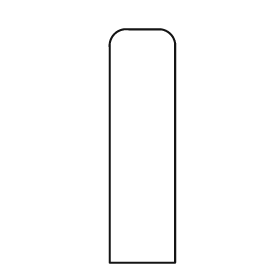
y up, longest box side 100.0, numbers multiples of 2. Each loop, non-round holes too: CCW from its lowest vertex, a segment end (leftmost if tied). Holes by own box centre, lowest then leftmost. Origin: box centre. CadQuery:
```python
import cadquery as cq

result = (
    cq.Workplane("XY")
    .moveTo(-14.0, -50.0)
    .lineTo(14.0, -50.0)
    .lineTo(14.0, 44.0)
    .threePointArc((12.0, 48.0), (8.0, 50.0))
    .lineTo(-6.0, 50.0)
    .threePointArc((-12.0, 48.0), (-14.0, 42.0))
    .close()
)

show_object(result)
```